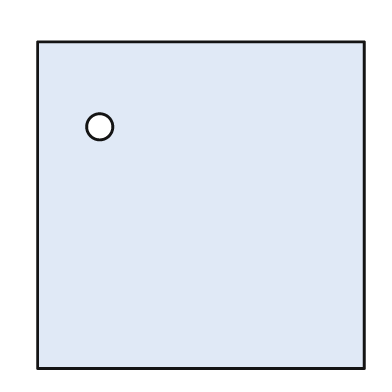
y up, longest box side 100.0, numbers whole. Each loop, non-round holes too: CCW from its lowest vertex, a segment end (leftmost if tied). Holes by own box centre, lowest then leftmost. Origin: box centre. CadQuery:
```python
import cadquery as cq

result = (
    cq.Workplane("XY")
    .moveTo(-50.0, -50.0)
    .lineTo(50.0, -50.0)
    .lineTo(50.0, 50.0)
    .lineTo(-50.0, 50.0)
    .close()
    .moveTo(-31.0, 24.0)
    .circle(4.0)
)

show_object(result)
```